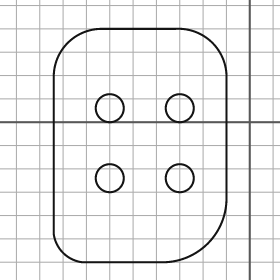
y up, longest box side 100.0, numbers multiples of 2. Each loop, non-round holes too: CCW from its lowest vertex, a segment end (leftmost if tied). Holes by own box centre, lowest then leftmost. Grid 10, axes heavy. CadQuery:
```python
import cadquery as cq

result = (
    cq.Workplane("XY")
    .moveTo(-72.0, -60.0)
    .lineTo(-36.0, -60.0)
    .threePointArc((-18.0, -52.0), (-10.0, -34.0))
    .lineTo(-10.0, 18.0)
    .threePointArc((-16.0, 34.0), (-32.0, 40.0))
    .lineTo(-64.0, 40.0)
    .threePointArc((-78.0, 34.0), (-84.0, 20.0))
    .lineTo(-84.0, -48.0)
    .threePointArc((-80.0, -56.0), (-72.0, -60.0))
    .close()
    .moveTo(-60.0, -24.0)
    .circle(6.0)
    .moveTo(-30.0, -24.0)
    .circle(6.0)
    .moveTo(-60.0, 6.0)
    .circle(6.0)
    .moveTo(-30.0, 6.0)
    .circle(6.0)
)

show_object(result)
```